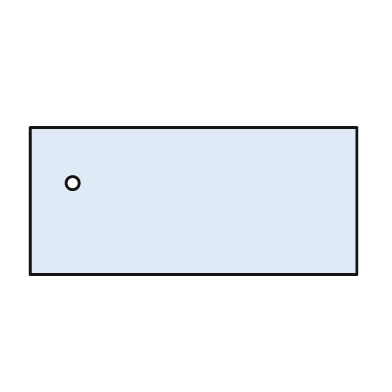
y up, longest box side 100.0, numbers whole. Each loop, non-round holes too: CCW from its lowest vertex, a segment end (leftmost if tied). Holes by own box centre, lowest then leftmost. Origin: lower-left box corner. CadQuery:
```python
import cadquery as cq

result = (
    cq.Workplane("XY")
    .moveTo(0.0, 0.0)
    .lineTo(100.0, 0.0)
    .lineTo(100.0, 45.0)
    .lineTo(0.0, 45.0)
    .close()
    .moveTo(13.0, 28.0)
    .circle(2.0)
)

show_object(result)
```